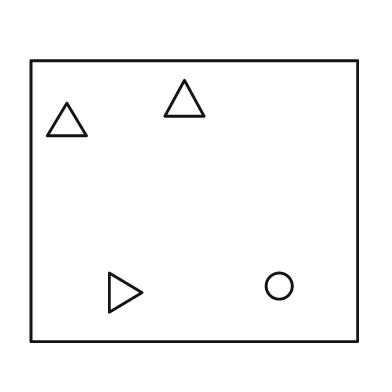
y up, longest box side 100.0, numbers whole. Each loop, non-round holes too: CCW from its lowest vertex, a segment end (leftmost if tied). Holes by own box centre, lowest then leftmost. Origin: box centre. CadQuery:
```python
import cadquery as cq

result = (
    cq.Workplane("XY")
    .moveTo(-50.0, -43.0)
    .lineTo(50.0, -43.0)
    .lineTo(50.0, 43.0)
    .lineTo(-50.0, 43.0)
    .close()
    .moveTo(-26.0, -34.0)
    .lineTo(-16.0, -28.0)
    .lineTo(-26.0, -22.0)
    .close()
    .moveTo(26.0, -26.0)
    .circle(4.0)
    .moveTo(-45.0, 20.0)
    .lineTo(-33.0, 20.0)
    .lineTo(-39.0, 30.0)
    .close()
    .moveTo(-9.0, 26.0)
    .lineTo(3.0, 26.0)
    .lineTo(-3.0, 37.0)
    .close()
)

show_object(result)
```